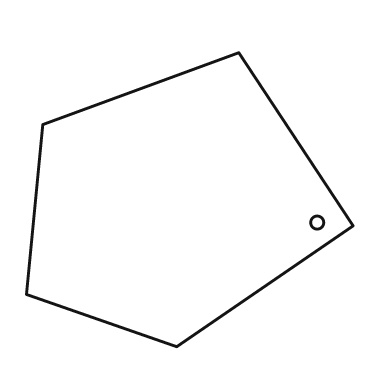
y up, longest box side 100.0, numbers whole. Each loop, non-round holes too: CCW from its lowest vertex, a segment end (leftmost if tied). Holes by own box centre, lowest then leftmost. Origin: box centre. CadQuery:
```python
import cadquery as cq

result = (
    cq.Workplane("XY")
    .moveTo(-4.0, -45.0)
    .lineTo(50.0, -8.0)
    .lineTo(15.0, 45.0)
    .lineTo(-45.0, 23.0)
    .lineTo(-50.0, -29.0)
    .close()
    .moveTo(39.0, -7.0)
    .circle(2.0)
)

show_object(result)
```